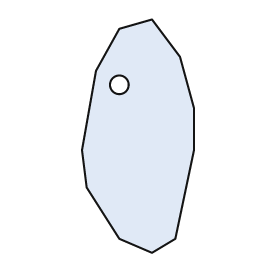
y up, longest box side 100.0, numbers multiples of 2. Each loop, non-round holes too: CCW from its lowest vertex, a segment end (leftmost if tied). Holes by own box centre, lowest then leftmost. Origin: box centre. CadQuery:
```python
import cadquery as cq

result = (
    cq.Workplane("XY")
    .moveTo(6.0, -50.0)
    .lineTo(16.0, -44.0)
    .lineTo(24.0, -6.0)
    .lineTo(24.0, 12.0)
    .lineTo(18.0, 34.0)
    .lineTo(6.0, 50.0)
    .lineTo(-8.0, 46.0)
    .lineTo(-18.0, 28.0)
    .lineTo(-24.0, -6.0)
    .lineTo(-22.0, -22.0)
    .lineTo(-8.0, -44.0)
    .close()
    .moveTo(-8.0, 22.0)
    .circle(4.0)
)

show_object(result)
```